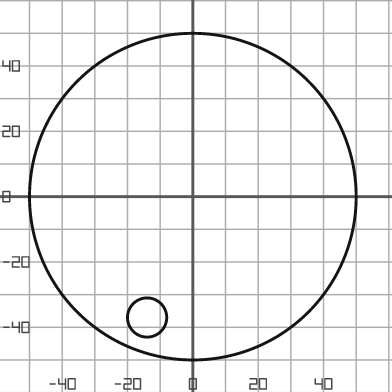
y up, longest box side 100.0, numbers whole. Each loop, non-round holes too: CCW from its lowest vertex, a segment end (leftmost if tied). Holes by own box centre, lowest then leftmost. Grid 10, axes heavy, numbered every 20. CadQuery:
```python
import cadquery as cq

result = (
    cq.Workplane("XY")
    .moveTo(0.0, 0.0)
    .circle(50.0)
    .moveTo(-14.0, -37.0)
    .circle(6.0)
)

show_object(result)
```